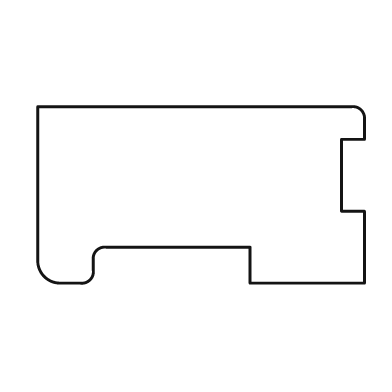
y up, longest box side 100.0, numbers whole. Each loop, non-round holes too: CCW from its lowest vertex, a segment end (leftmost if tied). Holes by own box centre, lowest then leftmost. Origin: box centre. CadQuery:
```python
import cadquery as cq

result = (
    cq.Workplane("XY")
    .moveTo(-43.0, -27.0)
    .lineTo(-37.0, -27.0)
    .threePointArc((-34.0, -26.0), (-33.0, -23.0))
    .lineTo(-33.0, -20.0)
    .threePointArc((-32.0, -17.0), (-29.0, -16.0))
    .lineTo(15.0, -16.0)
    .lineTo(15.0, -27.0)
    .lineTo(50.0, -27.0)
    .lineTo(50.0, -5.0)
    .lineTo(43.0, -5.0)
    .lineTo(43.0, 17.0)
    .lineTo(50.0, 17.0)
    .lineTo(50.0, 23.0)
    .threePointArc((49.0, 26.0), (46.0, 27.0))
    .lineTo(-50.0, 27.0)
    .lineTo(-50.0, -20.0)
    .threePointArc((-48.0, -25.0), (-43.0, -27.0))
    .close()
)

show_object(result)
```